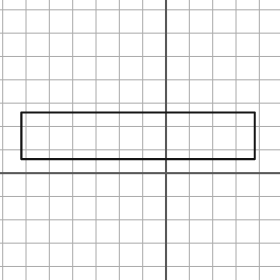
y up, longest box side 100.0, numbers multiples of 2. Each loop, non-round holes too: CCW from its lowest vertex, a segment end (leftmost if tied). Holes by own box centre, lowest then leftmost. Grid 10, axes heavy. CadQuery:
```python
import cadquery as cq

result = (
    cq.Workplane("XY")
    .moveTo(-62.0, 6.0)
    .lineTo(38.0, 6.0)
    .lineTo(38.0, 26.0)
    .lineTo(-62.0, 26.0)
    .close()
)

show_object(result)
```